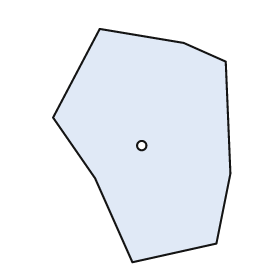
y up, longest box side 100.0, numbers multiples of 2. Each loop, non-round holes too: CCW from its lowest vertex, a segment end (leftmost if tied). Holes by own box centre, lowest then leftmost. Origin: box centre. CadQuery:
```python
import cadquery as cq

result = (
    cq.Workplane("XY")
    .moveTo(-4.0, -50.0)
    .lineTo(32.0, -42.0)
    .lineTo(38.0, -12.0)
    .lineTo(36.0, 36.0)
    .lineTo(18.0, 44.0)
    .lineTo(-18.0, 50.0)
    .lineTo(-38.0, 12.0)
    .lineTo(-20.0, -14.0)
    .close()
    .moveTo(0.0, 0.0)
    .circle(2.0)
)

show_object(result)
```